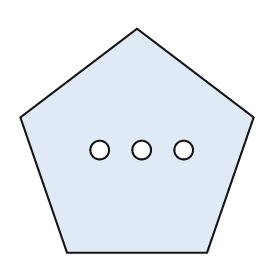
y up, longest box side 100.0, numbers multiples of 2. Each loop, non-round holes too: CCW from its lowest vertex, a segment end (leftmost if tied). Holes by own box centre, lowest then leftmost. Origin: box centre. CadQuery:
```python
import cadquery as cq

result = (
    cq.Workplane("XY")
    .moveTo(-30.0, -48.0)
    .lineTo(30.0, -48.0)
    .lineTo(50.0, 10.0)
    .lineTo(0.0, 48.0)
    .lineTo(-50.0, 10.0)
    .close()
    .moveTo(-16.0, -4.0)
    .circle(4.0)
    .moveTo(2.0, -4.0)
    .circle(4.0)
    .moveTo(20.0, -4.0)
    .circle(4.0)
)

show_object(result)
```